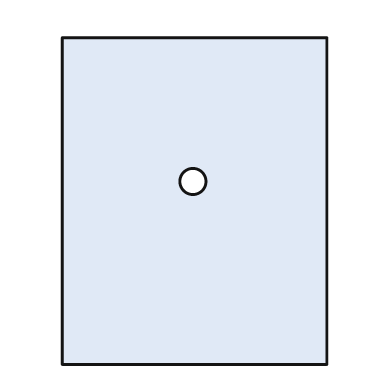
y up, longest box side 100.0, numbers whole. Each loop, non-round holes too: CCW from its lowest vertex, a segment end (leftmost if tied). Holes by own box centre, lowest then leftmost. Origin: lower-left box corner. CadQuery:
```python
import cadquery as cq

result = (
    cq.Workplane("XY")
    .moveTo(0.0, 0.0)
    .lineTo(81.0, 0.0)
    .lineTo(81.0, 100.0)
    .lineTo(0.0, 100.0)
    .close()
    .moveTo(40.0, 56.0)
    .circle(4.0)
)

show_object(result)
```